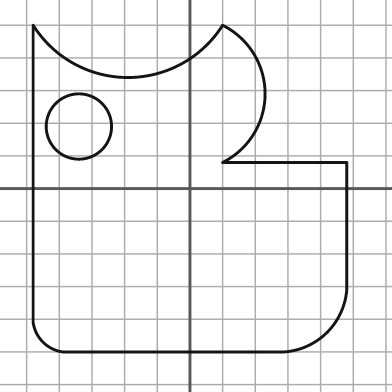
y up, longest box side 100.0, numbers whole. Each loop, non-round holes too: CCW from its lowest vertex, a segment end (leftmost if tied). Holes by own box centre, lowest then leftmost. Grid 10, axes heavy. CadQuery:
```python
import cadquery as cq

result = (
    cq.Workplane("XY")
    .moveTo(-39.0, -50.0)
    .lineTo(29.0, -50.0)
    .threePointArc((42.0, -44.0), (48.0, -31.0))
    .lineTo(48.0, 8.0)
    .lineTo(10.0, 8.0)
    .threePointArc((23.0, 29.0), (10.0, 50.0))
    .threePointArc((-19.0, 34.0), (-48.0, 50.0))
    .lineTo(-48.0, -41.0)
    .threePointArc((-45.0, -47.0), (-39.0, -50.0))
    .close()
    .moveTo(-34.0, 19.0)
    .circle(10.0)
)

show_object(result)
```